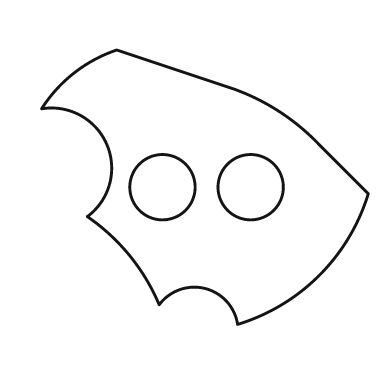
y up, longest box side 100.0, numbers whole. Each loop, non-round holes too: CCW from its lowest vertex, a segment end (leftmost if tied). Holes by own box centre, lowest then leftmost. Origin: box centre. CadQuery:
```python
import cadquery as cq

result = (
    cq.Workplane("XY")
    .moveTo(10.0, -42.0)
    .threePointArc((35.0, -27.0), (50.0, -2.0))
    .lineTo(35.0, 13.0)
    .threePointArc((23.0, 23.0), (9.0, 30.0))
    .lineTo(-27.0, 42.0)
    .threePointArc((-40.0, 35.0), (-50.0, 24.0))
    .threePointArc((-30.0, 13.0), (-36.0, -9.0))
    .threePointArc((-23.0, -21.0), (-14.0, -36.0))
    .threePointArc((0.0, -31.0), (10.0, -42.0))
    .close()
    .moveTo(-13.0, 0.0)
    .circle(10.0)
    .moveTo(14.0, 0.0)
    .circle(10.0)
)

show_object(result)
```